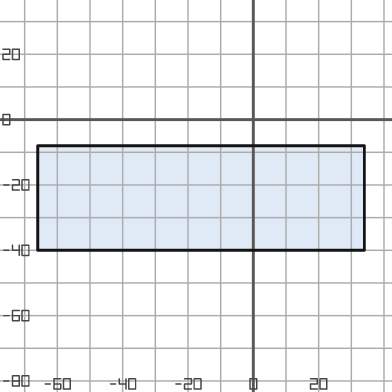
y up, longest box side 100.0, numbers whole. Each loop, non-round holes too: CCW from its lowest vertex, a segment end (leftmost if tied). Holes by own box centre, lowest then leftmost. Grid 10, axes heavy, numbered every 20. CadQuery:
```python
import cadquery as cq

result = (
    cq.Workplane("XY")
    .moveTo(-66.0, -40.0)
    .lineTo(34.0, -40.0)
    .lineTo(34.0, -8.0)
    .lineTo(-66.0, -8.0)
    .close()
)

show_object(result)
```